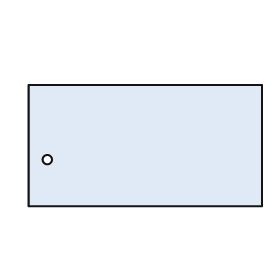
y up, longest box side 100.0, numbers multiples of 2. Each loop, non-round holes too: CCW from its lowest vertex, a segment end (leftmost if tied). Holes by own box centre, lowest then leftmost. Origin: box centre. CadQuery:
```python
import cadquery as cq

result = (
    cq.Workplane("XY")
    .moveTo(-50.0, -26.0)
    .lineTo(50.0, -26.0)
    .lineTo(50.0, 26.0)
    .lineTo(-50.0, 26.0)
    .close()
    .moveTo(-42.0, -6.0)
    .circle(2.0)
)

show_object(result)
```